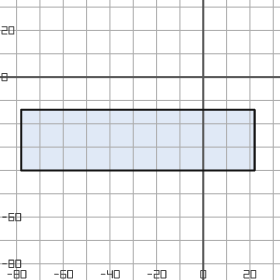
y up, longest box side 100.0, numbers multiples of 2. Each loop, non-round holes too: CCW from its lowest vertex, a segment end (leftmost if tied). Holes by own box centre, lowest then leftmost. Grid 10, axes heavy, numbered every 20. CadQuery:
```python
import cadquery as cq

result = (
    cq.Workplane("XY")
    .moveTo(-78.0, -40.0)
    .lineTo(22.0, -40.0)
    .lineTo(22.0, -14.0)
    .lineTo(-78.0, -14.0)
    .close()
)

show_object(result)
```